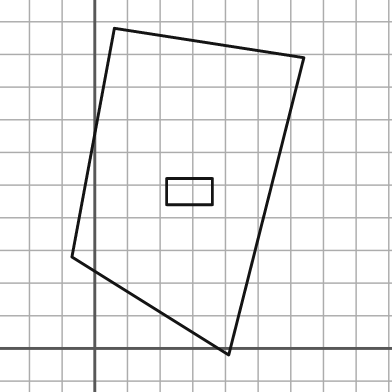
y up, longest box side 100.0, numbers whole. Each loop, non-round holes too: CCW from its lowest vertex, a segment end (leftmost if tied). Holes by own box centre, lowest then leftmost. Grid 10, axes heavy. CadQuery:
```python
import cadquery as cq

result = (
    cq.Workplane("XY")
    .moveTo(41.0, -2.0)
    .lineTo(64.0, 89.0)
    .lineTo(6.0, 98.0)
    .lineTo(-7.0, 28.0)
    .close()
    .moveTo(22.0, 44.0)
    .lineTo(36.0, 44.0)
    .lineTo(36.0, 52.0)
    .lineTo(22.0, 52.0)
    .close()
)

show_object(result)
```